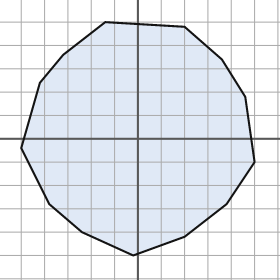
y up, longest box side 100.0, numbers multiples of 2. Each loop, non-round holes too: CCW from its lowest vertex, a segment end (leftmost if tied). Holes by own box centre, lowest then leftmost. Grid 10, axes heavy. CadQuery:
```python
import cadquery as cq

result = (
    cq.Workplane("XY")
    .moveTo(-2.0, -50.0)
    .lineTo(20.0, -42.0)
    .lineTo(38.0, -28.0)
    .lineTo(50.0, -10.0)
    .lineTo(46.0, 18.0)
    .lineTo(36.0, 34.0)
    .lineTo(20.0, 48.0)
    .lineTo(-14.0, 50.0)
    .lineTo(-32.0, 36.0)
    .lineTo(-42.0, 24.0)
    .lineTo(-50.0, -4.0)
    .lineTo(-38.0, -28.0)
    .lineTo(-24.0, -40.0)
    .close()
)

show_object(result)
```